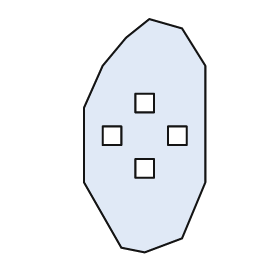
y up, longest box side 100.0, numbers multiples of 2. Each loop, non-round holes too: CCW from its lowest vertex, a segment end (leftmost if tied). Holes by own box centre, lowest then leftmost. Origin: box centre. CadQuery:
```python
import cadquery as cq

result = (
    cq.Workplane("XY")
    .moveTo(0.0, -50.0)
    .lineTo(16.0, -44.0)
    .lineTo(26.0, -20.0)
    .lineTo(26.0, 30.0)
    .lineTo(16.0, 46.0)
    .lineTo(2.0, 50.0)
    .lineTo(-8.0, 42.0)
    .lineTo(-18.0, 30.0)
    .lineTo(-26.0, 12.0)
    .lineTo(-26.0, -20.0)
    .lineTo(-10.0, -48.0)
    .close()
    .moveTo(-4.0, -18.0)
    .lineTo(4.0, -18.0)
    .lineTo(4.0, -10.0)
    .lineTo(-4.0, -10.0)
    .close()
    .moveTo(-18.0, -4.0)
    .lineTo(-10.0, -4.0)
    .lineTo(-10.0, 4.0)
    .lineTo(-18.0, 4.0)
    .close()
    .moveTo(10.0, -4.0)
    .lineTo(18.0, -4.0)
    .lineTo(18.0, 4.0)
    .lineTo(10.0, 4.0)
    .close()
    .moveTo(-4.0, 10.0)
    .lineTo(4.0, 10.0)
    .lineTo(4.0, 18.0)
    .lineTo(-4.0, 18.0)
    .close()
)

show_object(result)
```